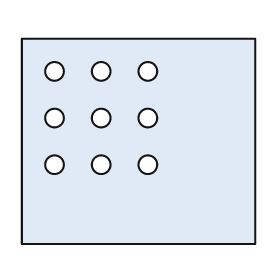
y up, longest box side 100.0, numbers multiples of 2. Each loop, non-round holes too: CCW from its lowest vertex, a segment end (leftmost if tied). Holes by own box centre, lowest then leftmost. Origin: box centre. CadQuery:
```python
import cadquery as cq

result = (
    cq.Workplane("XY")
    .moveTo(-50.0, -44.0)
    .lineTo(50.0, -44.0)
    .lineTo(50.0, 44.0)
    .lineTo(-50.0, 44.0)
    .close()
    .moveTo(-36.0, -10.0)
    .circle(4.0)
    .moveTo(-16.0, -10.0)
    .circle(4.0)
    .moveTo(4.0, -10.0)
    .circle(4.0)
    .moveTo(-36.0, 10.0)
    .circle(4.0)
    .moveTo(-16.0, 10.0)
    .circle(4.0)
    .moveTo(4.0, 10.0)
    .circle(4.0)
    .moveTo(-36.0, 30.0)
    .circle(4.0)
    .moveTo(-16.0, 30.0)
    .circle(4.0)
    .moveTo(4.0, 30.0)
    .circle(4.0)
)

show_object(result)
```